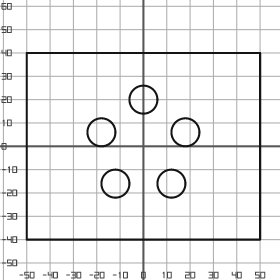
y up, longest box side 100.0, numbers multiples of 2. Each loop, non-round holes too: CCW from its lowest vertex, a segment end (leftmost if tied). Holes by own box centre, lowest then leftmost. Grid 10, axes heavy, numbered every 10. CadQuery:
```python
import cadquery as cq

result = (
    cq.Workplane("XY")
    .moveTo(-50.0, -40.0)
    .lineTo(50.0, -40.0)
    .lineTo(50.0, 40.0)
    .lineTo(-50.0, 40.0)
    .close()
    .moveTo(-12.0, -16.0)
    .circle(6.0)
    .moveTo(12.0, -16.0)
    .circle(6.0)
    .moveTo(-18.0, 6.0)
    .circle(6.0)
    .moveTo(18.0, 6.0)
    .circle(6.0)
    .moveTo(0.0, 20.0)
    .circle(6.0)
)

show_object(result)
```